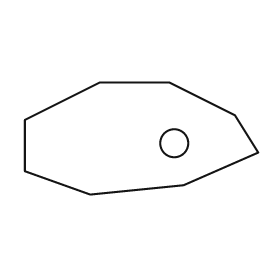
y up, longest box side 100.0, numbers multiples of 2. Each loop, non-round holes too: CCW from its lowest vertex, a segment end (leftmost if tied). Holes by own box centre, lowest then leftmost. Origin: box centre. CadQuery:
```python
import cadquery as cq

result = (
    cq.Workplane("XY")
    .moveTo(-22.0, -24.0)
    .lineTo(18.0, -20.0)
    .lineTo(50.0, -6.0)
    .lineTo(40.0, 10.0)
    .lineTo(12.0, 24.0)
    .lineTo(-18.0, 24.0)
    .lineTo(-50.0, 8.0)
    .lineTo(-50.0, -14.0)
    .close()
    .moveTo(14.0, -2.0)
    .circle(6.0)
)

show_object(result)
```